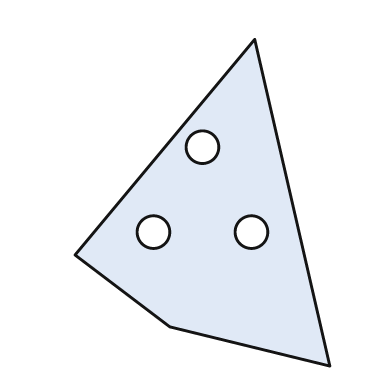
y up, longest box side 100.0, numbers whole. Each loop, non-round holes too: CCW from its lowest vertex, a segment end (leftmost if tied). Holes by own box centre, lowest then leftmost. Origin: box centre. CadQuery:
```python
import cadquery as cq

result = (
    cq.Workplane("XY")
    .moveTo(39.0, -50.0)
    .lineTo(16.0, 50.0)
    .lineTo(-39.0, -16.0)
    .lineTo(-10.0, -38.0)
    .close()
    .moveTo(-15.0, -9.0)
    .circle(5.0)
    .moveTo(15.0, -9.0)
    .circle(5.0)
    .moveTo(0.0, 17.0)
    .circle(5.0)
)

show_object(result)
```